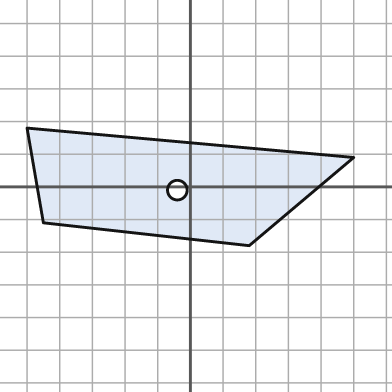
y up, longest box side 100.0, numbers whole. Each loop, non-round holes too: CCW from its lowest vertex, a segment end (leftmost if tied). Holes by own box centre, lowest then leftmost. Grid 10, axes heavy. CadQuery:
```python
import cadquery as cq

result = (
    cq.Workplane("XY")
    .moveTo(18.0, -18.0)
    .lineTo(50.0, 9.0)
    .lineTo(-50.0, 18.0)
    .lineTo(-45.0, -11.0)
    .close()
    .moveTo(-4.0, -1.0)
    .circle(3.0)
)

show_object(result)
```